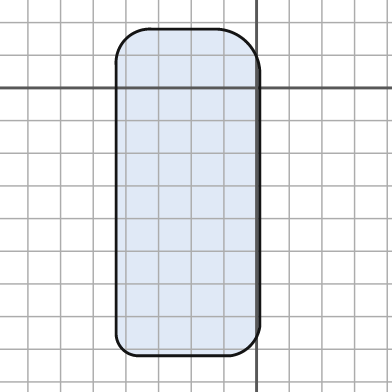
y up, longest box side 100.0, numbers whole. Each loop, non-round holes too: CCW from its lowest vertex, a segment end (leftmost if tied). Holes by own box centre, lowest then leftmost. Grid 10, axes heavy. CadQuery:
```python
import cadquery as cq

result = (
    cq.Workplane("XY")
    .moveTo(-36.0, -82.0)
    .lineTo(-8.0, -82.0)
    .threePointArc((-2.0, -79.0), (1.0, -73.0))
    .lineTo(1.0, 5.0)
    .threePointArc((-3.0, 14.0), (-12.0, 18.0))
    .lineTo(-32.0, 18.0)
    .threePointArc((-40.0, 15.0), (-43.0, 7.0))
    .lineTo(-43.0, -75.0)
    .threePointArc((-41.0, -80.0), (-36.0, -82.0))
    .close()
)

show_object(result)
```